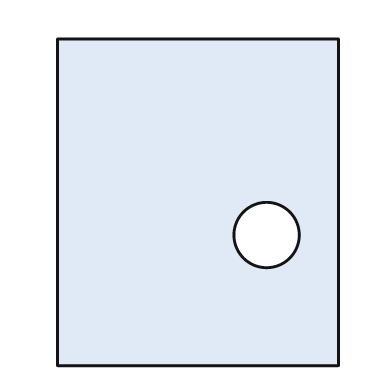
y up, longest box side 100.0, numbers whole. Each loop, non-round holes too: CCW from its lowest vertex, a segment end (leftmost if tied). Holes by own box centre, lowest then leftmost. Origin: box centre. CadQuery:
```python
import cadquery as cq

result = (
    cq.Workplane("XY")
    .moveTo(-43.0, -50.0)
    .lineTo(43.0, -50.0)
    .lineTo(43.0, 50.0)
    .lineTo(-43.0, 50.0)
    .close()
    .moveTo(21.0, -10.0)
    .circle(10.0)
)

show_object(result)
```